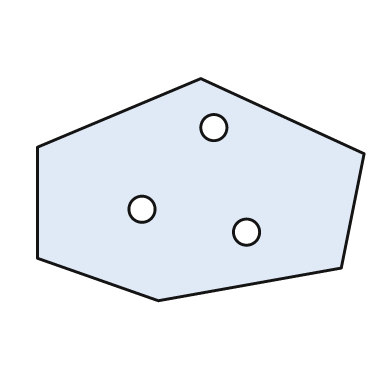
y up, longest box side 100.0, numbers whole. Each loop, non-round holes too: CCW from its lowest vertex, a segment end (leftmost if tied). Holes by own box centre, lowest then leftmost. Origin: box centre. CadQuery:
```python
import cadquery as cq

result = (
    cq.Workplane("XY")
    .moveTo(-13.0, -34.0)
    .lineTo(43.0, -24.0)
    .lineTo(50.0, 11.0)
    .lineTo(0.0, 34.0)
    .lineTo(-50.0, 13.0)
    .lineTo(-50.0, -21.0)
    .close()
    .moveTo(14.0, -13.0)
    .circle(4.0)
    .moveTo(-18.0, -6.0)
    .circle(4.0)
    .moveTo(4.0, 19.0)
    .circle(4.0)
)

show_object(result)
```